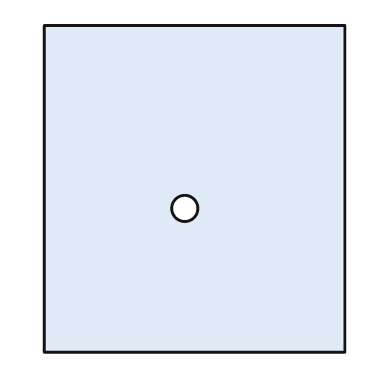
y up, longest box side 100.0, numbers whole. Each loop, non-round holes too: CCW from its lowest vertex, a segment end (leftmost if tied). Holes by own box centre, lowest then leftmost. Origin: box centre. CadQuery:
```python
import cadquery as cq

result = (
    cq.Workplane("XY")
    .moveTo(-46.0, -50.0)
    .lineTo(46.0, -50.0)
    .lineTo(46.0, 50.0)
    .lineTo(-46.0, 50.0)
    .close()
    .moveTo(-3.0, -6.0)
    .circle(4.0)
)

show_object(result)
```